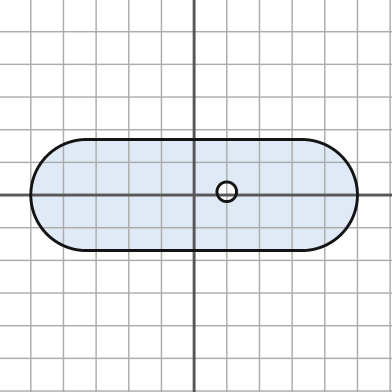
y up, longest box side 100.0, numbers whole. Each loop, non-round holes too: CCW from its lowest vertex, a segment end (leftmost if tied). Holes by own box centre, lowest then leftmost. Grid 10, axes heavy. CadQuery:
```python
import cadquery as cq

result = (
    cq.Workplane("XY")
    .moveTo(-33.0, -17.0)
    .lineTo(33.0, -17.0)
    .threePointArc((50.0, 0.0), (33.0, 17.0))
    .lineTo(-33.0, 17.0)
    .threePointArc((-50.0, 0.0), (-33.0, -17.0))
    .close()
    .moveTo(10.0, 1.0)
    .circle(3.0)
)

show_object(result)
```